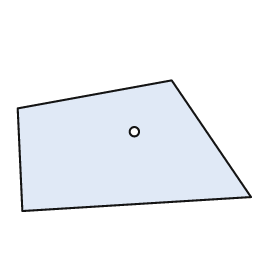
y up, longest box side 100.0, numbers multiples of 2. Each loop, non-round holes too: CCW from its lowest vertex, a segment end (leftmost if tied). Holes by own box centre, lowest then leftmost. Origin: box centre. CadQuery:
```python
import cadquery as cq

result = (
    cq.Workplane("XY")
    .moveTo(-48.0, -28.0)
    .lineTo(50.0, -22.0)
    .lineTo(16.0, 28.0)
    .lineTo(-50.0, 16.0)
    .close()
    .moveTo(0.0, 6.0)
    .circle(2.0)
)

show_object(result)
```